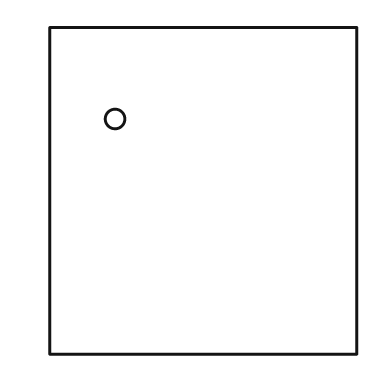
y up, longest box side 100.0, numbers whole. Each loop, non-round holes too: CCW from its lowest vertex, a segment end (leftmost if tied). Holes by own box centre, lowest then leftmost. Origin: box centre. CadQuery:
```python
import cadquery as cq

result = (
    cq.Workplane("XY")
    .moveTo(-47.0, -50.0)
    .lineTo(47.0, -50.0)
    .lineTo(47.0, 50.0)
    .lineTo(-47.0, 50.0)
    .close()
    .moveTo(-27.0, 22.0)
    .circle(3.0)
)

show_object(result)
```